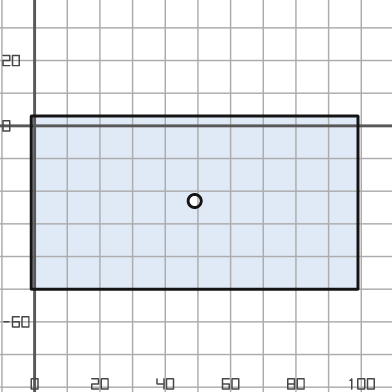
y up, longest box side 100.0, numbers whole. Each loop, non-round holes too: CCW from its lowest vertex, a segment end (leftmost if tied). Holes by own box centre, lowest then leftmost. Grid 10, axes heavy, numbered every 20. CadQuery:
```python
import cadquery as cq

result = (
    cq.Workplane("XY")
    .moveTo(-1.0, -50.0)
    .lineTo(99.0, -50.0)
    .lineTo(99.0, 3.0)
    .lineTo(-1.0, 3.0)
    .close()
    .moveTo(49.0, -23.0)
    .circle(2.0)
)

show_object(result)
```